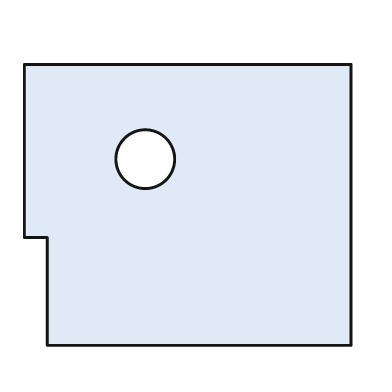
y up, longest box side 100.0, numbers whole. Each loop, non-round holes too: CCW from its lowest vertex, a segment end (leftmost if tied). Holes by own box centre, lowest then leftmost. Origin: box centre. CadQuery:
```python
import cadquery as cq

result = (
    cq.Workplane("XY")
    .moveTo(-43.0, -43.0)
    .lineTo(50.0, -43.0)
    .lineTo(50.0, 43.0)
    .lineTo(-50.0, 43.0)
    .lineTo(-50.0, -10.0)
    .lineTo(-43.0, -10.0)
    .close()
    .moveTo(-13.0, 14.0)
    .circle(9.0)
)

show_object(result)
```